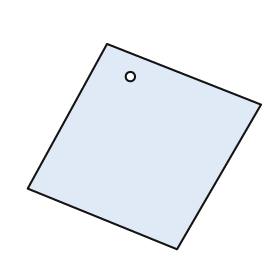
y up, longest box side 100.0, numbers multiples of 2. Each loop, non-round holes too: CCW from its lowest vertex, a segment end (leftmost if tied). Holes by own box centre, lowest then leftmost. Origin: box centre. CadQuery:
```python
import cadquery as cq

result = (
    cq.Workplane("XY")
    .moveTo(14.0, -44.0)
    .lineTo(50.0, 18.0)
    .lineTo(-16.0, 44.0)
    .lineTo(-50.0, -18.0)
    .close()
    .moveTo(-6.0, 30.0)
    .circle(2.0)
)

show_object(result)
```